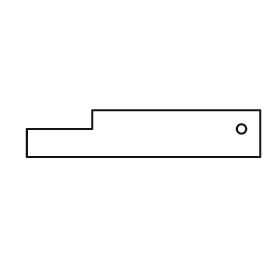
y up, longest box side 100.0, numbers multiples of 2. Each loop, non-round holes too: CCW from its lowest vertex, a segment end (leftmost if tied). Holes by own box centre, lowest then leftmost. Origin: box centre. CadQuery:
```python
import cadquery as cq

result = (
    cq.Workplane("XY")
    .moveTo(-50.0, -10.0)
    .lineTo(50.0, -10.0)
    .lineTo(50.0, 10.0)
    .lineTo(-22.0, 10.0)
    .lineTo(-22.0, 2.0)
    .lineTo(-50.0, 2.0)
    .close()
    .moveTo(42.0, 2.0)
    .circle(2.0)
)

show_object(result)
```